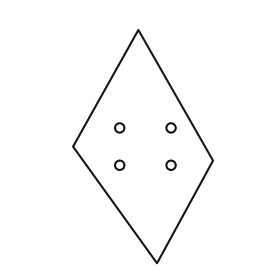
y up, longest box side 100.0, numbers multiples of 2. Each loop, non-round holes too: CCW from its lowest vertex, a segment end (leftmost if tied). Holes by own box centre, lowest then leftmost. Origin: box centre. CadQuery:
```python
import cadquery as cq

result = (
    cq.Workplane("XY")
    .moveTo(6.0, -50.0)
    .lineTo(30.0, -6.0)
    .lineTo(-2.0, 50.0)
    .lineTo(-30.0, 0.0)
    .close()
    .moveTo(-10.0, -8.0)
    .circle(2.0)
    .moveTo(12.0, -8.0)
    .circle(2.0)
    .moveTo(-10.0, 8.0)
    .circle(2.0)
    .moveTo(12.0, 8.0)
    .circle(2.0)
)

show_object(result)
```